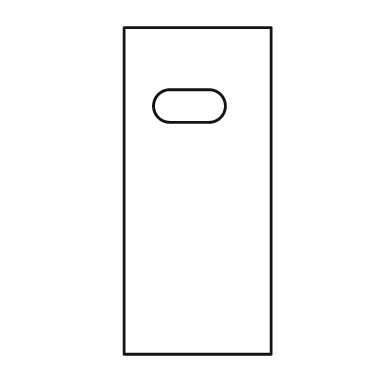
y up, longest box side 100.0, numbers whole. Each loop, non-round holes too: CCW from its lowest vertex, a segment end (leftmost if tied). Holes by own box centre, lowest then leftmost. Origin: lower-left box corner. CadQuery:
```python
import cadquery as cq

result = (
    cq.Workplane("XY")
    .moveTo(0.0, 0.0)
    .lineTo(45.0, 0.0)
    .lineTo(45.0, 100.0)
    .lineTo(0.0, 100.0)
    .close()
    .moveTo(14.0, 71.0)
    .lineTo(26.0, 71.0)
    .threePointArc((31.0, 76.0), (26.0, 81.0))
    .lineTo(14.0, 81.0)
    .threePointArc((9.0, 76.0), (14.0, 71.0))
    .close()
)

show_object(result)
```